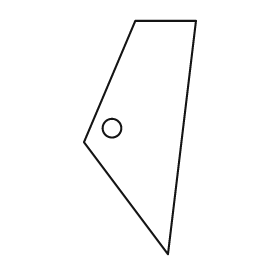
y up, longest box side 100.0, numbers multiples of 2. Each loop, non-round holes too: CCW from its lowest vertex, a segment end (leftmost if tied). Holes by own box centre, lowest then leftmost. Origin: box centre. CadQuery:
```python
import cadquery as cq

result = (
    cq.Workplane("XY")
    .moveTo(12.0, -50.0)
    .lineTo(24.0, 50.0)
    .lineTo(-2.0, 50.0)
    .lineTo(-24.0, -2.0)
    .close()
    .moveTo(-12.0, 4.0)
    .circle(4.0)
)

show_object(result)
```